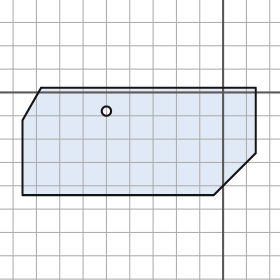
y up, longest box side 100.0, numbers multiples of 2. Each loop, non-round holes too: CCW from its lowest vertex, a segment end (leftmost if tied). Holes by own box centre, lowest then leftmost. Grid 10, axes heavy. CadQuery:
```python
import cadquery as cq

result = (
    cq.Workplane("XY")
    .moveTo(-86.0, -44.0)
    .lineTo(-4.0, -44.0)
    .lineTo(14.0, -26.0)
    .lineTo(14.0, 2.0)
    .lineTo(-78.0, 2.0)
    .lineTo(-86.0, -12.0)
    .close()
    .moveTo(-50.0, -8.0)
    .circle(2.0)
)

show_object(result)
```